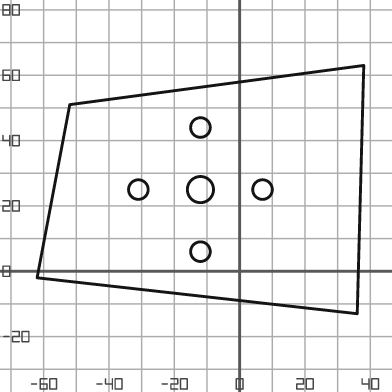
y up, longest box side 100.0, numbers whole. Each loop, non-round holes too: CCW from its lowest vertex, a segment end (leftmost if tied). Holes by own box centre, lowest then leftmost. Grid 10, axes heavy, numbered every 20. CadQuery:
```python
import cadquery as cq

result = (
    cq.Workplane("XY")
    .moveTo(36.0, -13.0)
    .lineTo(38.0, 63.0)
    .lineTo(-52.0, 51.0)
    .lineTo(-62.0, -2.0)
    .close()
    .moveTo(-12.0, 6.0)
    .circle(3.0)
    .moveTo(-31.0, 25.0)
    .circle(3.0)
    .moveTo(-12.0, 25.0)
    .circle(4.0)
    .moveTo(7.0, 25.0)
    .circle(3.0)
    .moveTo(-12.0, 44.0)
    .circle(3.0)
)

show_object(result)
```